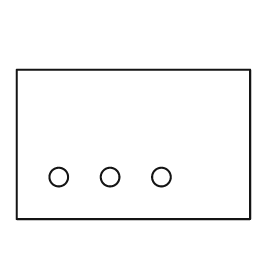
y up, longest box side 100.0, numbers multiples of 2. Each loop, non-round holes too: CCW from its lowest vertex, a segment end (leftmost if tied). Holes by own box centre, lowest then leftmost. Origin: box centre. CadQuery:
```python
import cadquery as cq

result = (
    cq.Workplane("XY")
    .moveTo(-50.0, -32.0)
    .lineTo(50.0, -32.0)
    .lineTo(50.0, 32.0)
    .lineTo(-50.0, 32.0)
    .close()
    .moveTo(-32.0, -14.0)
    .circle(4.0)
    .moveTo(-10.0, -14.0)
    .circle(4.0)
    .moveTo(12.0, -14.0)
    .circle(4.0)
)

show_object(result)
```